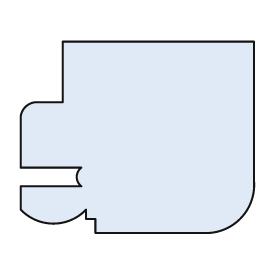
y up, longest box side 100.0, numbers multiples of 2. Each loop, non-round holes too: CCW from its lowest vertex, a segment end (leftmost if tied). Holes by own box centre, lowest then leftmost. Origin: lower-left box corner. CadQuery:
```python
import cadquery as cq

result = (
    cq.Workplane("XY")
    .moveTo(32.0, 0.0)
    .lineTo(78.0, 0.0)
    .threePointArc((94.0, 6.0), (100.0, 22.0))
    .lineTo(100.0, 82.0)
    .lineTo(18.0, 82.0)
    .lineTo(18.0, 56.0)
    .lineTo(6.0, 56.0)
    .threePointArc((2.0, 54.0), (0.0, 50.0))
    .lineTo(0.0, 28.0)
    .lineTo(26.0, 28.0)
    .threePointArc((24.0, 24.0), (26.0, 20.0))
    .lineTo(0.0, 20.0)
    .lineTo(0.0, 10.0)
    .threePointArc((14.0, 4.0), (28.0, 10.0))
    .lineTo(28.0, 6.0)
    .lineTo(32.0, 6.0)
    .close()
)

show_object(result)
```